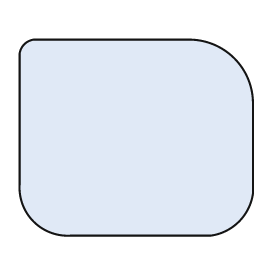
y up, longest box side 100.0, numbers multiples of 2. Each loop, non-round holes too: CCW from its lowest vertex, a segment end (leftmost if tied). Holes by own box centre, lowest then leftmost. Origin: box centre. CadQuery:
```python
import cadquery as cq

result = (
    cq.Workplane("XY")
    .moveTo(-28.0, -42.0)
    .lineTo(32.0, -42.0)
    .threePointArc((44.0, -36.0), (50.0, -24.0))
    .lineTo(50.0, 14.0)
    .threePointArc((42.0, 34.0), (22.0, 42.0))
    .lineTo(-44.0, 42.0)
    .threePointArc((-48.0, 40.0), (-50.0, 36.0))
    .lineTo(-50.0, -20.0)
    .threePointArc((-44.0, -36.0), (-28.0, -42.0))
    .close()
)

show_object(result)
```